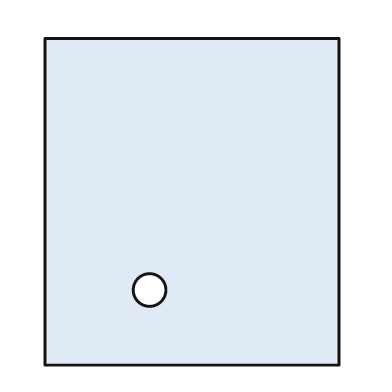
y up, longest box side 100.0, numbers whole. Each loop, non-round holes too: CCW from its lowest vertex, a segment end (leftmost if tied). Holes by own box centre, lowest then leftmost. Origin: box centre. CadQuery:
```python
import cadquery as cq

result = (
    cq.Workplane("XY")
    .moveTo(-45.0, -50.0)
    .lineTo(45.0, -50.0)
    .lineTo(45.0, 50.0)
    .lineTo(-45.0, 50.0)
    .close()
    .moveTo(-13.0, -27.0)
    .circle(5.0)
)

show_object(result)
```